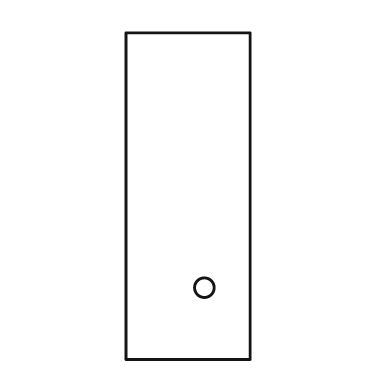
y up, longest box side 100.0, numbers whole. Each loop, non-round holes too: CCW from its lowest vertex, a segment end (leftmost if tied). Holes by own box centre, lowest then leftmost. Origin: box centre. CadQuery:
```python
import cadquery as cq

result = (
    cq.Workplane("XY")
    .moveTo(-19.0, -50.0)
    .lineTo(19.0, -50.0)
    .lineTo(19.0, 50.0)
    .lineTo(-19.0, 50.0)
    .close()
    .moveTo(5.0, -28.0)
    .circle(3.0)
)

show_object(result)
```